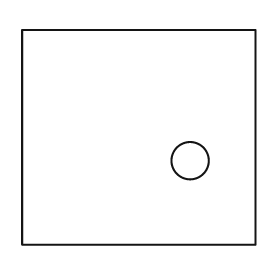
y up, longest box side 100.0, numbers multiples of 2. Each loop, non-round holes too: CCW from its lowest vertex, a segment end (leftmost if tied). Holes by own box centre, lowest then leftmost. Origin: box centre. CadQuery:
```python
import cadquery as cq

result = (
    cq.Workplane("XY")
    .moveTo(-50.0, -46.0)
    .lineTo(50.0, -46.0)
    .lineTo(50.0, 46.0)
    .lineTo(-50.0, 46.0)
    .close()
    .moveTo(22.0, -10.0)
    .circle(8.0)
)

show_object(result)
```